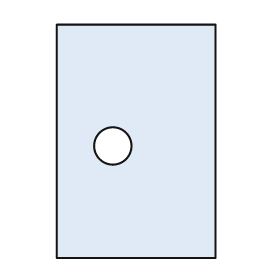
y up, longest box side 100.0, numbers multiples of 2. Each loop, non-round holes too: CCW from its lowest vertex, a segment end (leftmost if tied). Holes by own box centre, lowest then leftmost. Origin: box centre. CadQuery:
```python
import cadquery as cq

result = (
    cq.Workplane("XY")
    .moveTo(-34.0, -50.0)
    .lineTo(34.0, -50.0)
    .lineTo(34.0, 50.0)
    .lineTo(-34.0, 50.0)
    .close()
    .moveTo(-10.0, -2.0)
    .circle(8.0)
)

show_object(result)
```